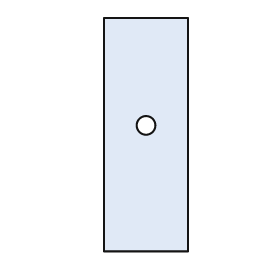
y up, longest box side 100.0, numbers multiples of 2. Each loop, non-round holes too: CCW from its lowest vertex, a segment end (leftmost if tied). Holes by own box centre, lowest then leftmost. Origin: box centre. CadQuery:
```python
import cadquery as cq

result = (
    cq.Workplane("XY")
    .moveTo(-18.0, -50.0)
    .lineTo(18.0, -50.0)
    .lineTo(18.0, 50.0)
    .lineTo(-18.0, 50.0)
    .close()
    .moveTo(0.0, 4.0)
    .circle(4.0)
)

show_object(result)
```